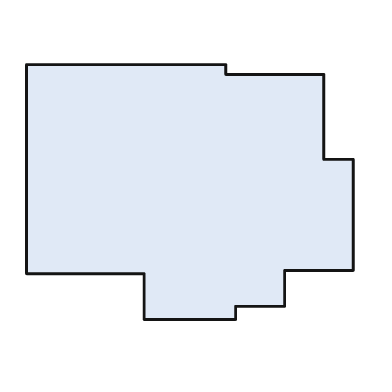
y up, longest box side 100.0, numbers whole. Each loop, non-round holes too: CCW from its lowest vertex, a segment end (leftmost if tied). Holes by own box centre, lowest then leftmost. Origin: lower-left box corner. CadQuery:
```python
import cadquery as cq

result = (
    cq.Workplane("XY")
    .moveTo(36.0, 0.0)
    .lineTo(64.0, 0.0)
    .lineTo(64.0, 4.0)
    .lineTo(79.0, 4.0)
    .lineTo(79.0, 15.0)
    .lineTo(100.0, 15.0)
    .lineTo(100.0, 49.0)
    .lineTo(91.0, 49.0)
    .lineTo(91.0, 75.0)
    .lineTo(61.0, 75.0)
    .lineTo(61.0, 78.0)
    .lineTo(0.0, 78.0)
    .lineTo(0.0, 14.0)
    .lineTo(36.0, 14.0)
    .close()
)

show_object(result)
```